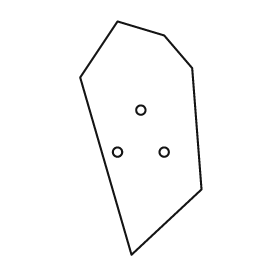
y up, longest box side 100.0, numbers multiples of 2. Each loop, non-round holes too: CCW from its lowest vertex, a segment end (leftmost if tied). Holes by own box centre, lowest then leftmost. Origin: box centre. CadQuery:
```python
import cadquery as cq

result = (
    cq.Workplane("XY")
    .moveTo(-4.0, -50.0)
    .lineTo(26.0, -22.0)
    .lineTo(22.0, 30.0)
    .lineTo(10.0, 44.0)
    .lineTo(-10.0, 50.0)
    .lineTo(-26.0, 26.0)
    .close()
    .moveTo(-10.0, -6.0)
    .circle(2.0)
    .moveTo(10.0, -6.0)
    .circle(2.0)
    .moveTo(0.0, 12.0)
    .circle(2.0)
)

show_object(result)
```